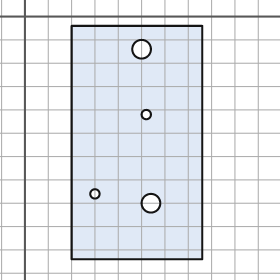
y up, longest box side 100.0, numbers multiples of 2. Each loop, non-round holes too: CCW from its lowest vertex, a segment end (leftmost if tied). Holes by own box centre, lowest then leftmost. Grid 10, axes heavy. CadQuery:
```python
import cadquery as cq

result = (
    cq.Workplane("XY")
    .moveTo(20.0, -104.0)
    .lineTo(76.0, -104.0)
    .lineTo(76.0, -4.0)
    .lineTo(20.0, -4.0)
    .close()
    .moveTo(54.0, -80.0)
    .circle(4.0)
    .moveTo(30.0, -76.0)
    .circle(2.0)
    .moveTo(52.0, -42.0)
    .circle(2.0)
    .moveTo(50.0, -14.0)
    .circle(4.0)
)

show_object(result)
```